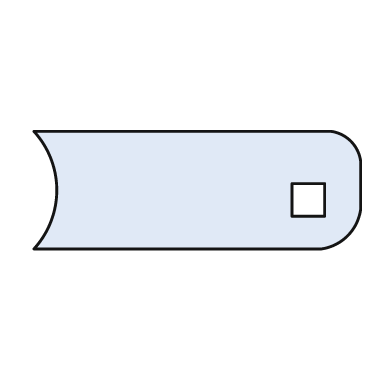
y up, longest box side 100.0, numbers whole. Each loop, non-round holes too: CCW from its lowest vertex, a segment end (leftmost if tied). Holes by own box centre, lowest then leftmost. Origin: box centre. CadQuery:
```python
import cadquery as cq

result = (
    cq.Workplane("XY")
    .moveTo(-50.0, -18.0)
    .lineTo(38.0, -18.0)
    .threePointArc((46.0, -14.0), (50.0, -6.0))
    .lineTo(50.0, 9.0)
    .threePointArc((47.0, 15.0), (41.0, 18.0))
    .lineTo(-50.0, 18.0)
    .threePointArc((-43.0, 0.0), (-50.0, -18.0))
    .close()
    .moveTo(29.0, -8.0)
    .lineTo(39.0, -8.0)
    .lineTo(39.0, 2.0)
    .lineTo(29.0, 2.0)
    .close()
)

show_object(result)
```